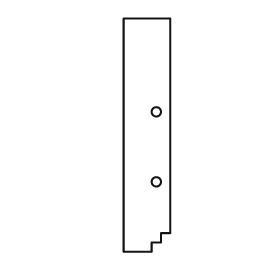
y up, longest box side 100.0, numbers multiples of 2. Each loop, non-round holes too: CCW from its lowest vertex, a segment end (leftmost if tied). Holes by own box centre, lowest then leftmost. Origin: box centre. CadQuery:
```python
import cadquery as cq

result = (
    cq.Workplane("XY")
    .moveTo(-10.0, -50.0)
    .lineTo(2.0, -50.0)
    .lineTo(2.0, -46.0)
    .lineTo(6.0, -46.0)
    .lineTo(6.0, -42.0)
    .lineTo(10.0, -42.0)
    .lineTo(10.0, 50.0)
    .lineTo(-10.0, 50.0)
    .close()
    .moveTo(4.0, -20.0)
    .circle(2.0)
    .moveTo(4.0, 10.0)
    .circle(2.0)
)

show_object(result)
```